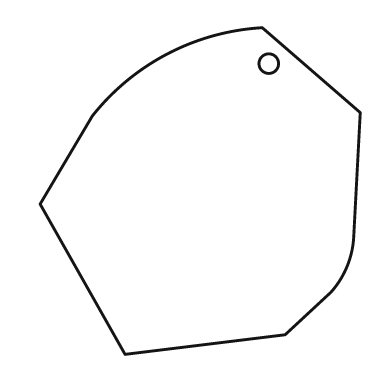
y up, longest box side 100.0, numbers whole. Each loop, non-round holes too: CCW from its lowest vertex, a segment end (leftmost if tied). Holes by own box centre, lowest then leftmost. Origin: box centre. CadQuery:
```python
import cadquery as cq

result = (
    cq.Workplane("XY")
    .moveTo(-23.0, -50.0)
    .lineTo(26.0, -44.0)
    .lineTo(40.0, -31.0)
    .threePointArc((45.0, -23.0), (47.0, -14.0))
    .lineTo(49.0, 24.0)
    .lineTo(19.0, 50.0)
    .threePointArc((-10.0, 42.0), (-33.0, 23.0))
    .lineTo(-49.0, -4.0)
    .close()
    .moveTo(21.0, 39.0)
    .circle(3.0)
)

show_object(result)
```